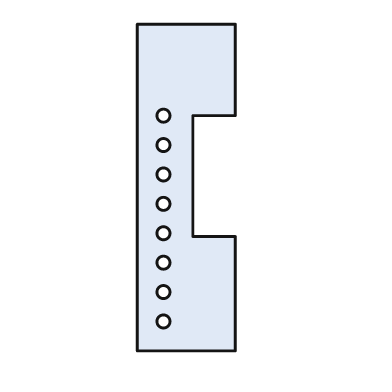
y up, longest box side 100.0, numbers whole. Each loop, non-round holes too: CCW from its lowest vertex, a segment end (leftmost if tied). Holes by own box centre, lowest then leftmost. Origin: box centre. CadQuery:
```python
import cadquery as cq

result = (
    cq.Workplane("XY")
    .moveTo(-15.0, -50.0)
    .lineTo(15.0, -50.0)
    .lineTo(15.0, -15.0)
    .lineTo(2.0, -15.0)
    .lineTo(2.0, 22.0)
    .lineTo(15.0, 22.0)
    .lineTo(15.0, 50.0)
    .lineTo(-15.0, 50.0)
    .close()
    .moveTo(-7.0, -41.0)
    .circle(2.0)
    .moveTo(-7.0, -32.0)
    .circle(2.0)
    .moveTo(-7.0, -23.0)
    .circle(2.0)
    .moveTo(-7.0, -14.0)
    .circle(2.0)
    .moveTo(-7.0, -5.0)
    .circle(2.0)
    .moveTo(-7.0, 4.0)
    .circle(2.0)
    .moveTo(-7.0, 13.0)
    .circle(2.0)
    .moveTo(-7.0, 22.0)
    .circle(2.0)
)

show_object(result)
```